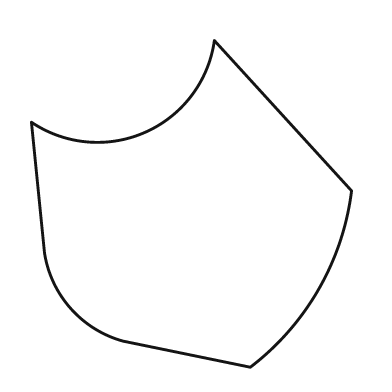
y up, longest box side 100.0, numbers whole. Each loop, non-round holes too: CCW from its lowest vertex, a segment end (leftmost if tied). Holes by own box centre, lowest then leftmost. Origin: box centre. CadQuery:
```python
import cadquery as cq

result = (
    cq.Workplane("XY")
    .moveTo(18.0, -50.0)
    .threePointArc((39.0, -26.0), (49.0, 4.0))
    .lineTo(7.0, 50.0)
    .threePointArc((-14.0, 22.0), (-49.0, 25.0))
    .lineTo(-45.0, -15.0)
    .threePointArc((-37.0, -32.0), (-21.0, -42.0))
    .close()
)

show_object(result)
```